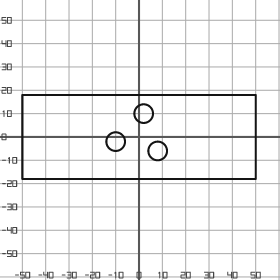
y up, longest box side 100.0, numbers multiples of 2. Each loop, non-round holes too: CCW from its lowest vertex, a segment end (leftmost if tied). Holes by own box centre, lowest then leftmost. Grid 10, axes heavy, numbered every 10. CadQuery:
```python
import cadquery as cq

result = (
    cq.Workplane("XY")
    .moveTo(-50.0, -18.0)
    .lineTo(50.0, -18.0)
    .lineTo(50.0, 18.0)
    .lineTo(-50.0, 18.0)
    .close()
    .moveTo(8.0, -6.0)
    .circle(4.0)
    .moveTo(-10.0, -2.0)
    .circle(4.0)
    .moveTo(2.0, 10.0)
    .circle(4.0)
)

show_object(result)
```